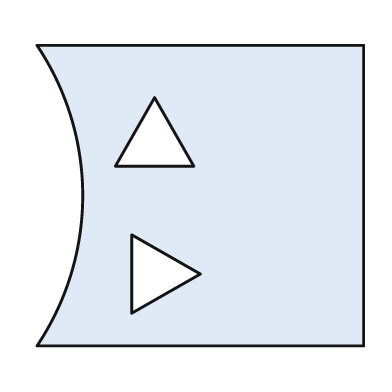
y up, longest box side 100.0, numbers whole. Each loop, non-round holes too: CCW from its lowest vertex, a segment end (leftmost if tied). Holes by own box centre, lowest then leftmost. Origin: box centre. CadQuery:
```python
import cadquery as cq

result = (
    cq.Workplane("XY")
    .moveTo(-50.0, -46.0)
    .lineTo(50.0, -46.0)
    .lineTo(50.0, 46.0)
    .lineTo(-50.0, 46.0)
    .threePointArc((-36.0, 0.0), (-50.0, -46.0))
    .close()
    .moveTo(-21.0, -36.0)
    .lineTo(0.0, -24.0)
    .lineTo(-21.0, -12.0)
    .close()
    .moveTo(-26.0, 9.0)
    .lineTo(-2.0, 9.0)
    .lineTo(-14.0, 30.0)
    .close()
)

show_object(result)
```